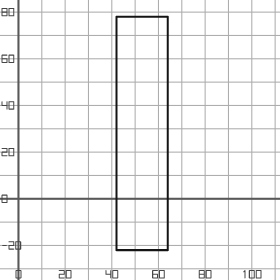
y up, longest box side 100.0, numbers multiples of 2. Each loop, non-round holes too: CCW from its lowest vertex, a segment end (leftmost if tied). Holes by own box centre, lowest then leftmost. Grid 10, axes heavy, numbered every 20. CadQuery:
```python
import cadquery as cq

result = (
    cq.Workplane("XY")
    .moveTo(42.0, -22.0)
    .lineTo(64.0, -22.0)
    .lineTo(64.0, 78.0)
    .lineTo(42.0, 78.0)
    .close()
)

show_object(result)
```